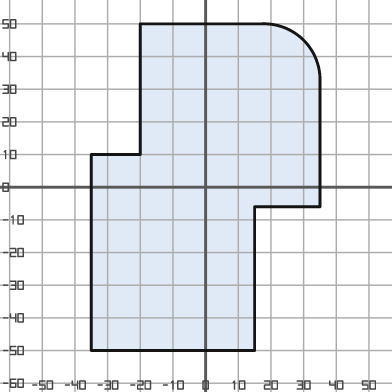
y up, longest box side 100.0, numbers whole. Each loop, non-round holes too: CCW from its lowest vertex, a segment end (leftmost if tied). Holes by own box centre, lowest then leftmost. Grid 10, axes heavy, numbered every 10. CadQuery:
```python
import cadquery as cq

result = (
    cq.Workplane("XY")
    .moveTo(-35.0, -50.0)
    .lineTo(15.0, -50.0)
    .lineTo(15.0, -6.0)
    .lineTo(35.0, -6.0)
    .lineTo(35.0, 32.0)
    .threePointArc((30.0, 45.0), (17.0, 50.0))
    .lineTo(-20.0, 50.0)
    .lineTo(-20.0, 10.0)
    .lineTo(-35.0, 10.0)
    .close()
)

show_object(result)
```